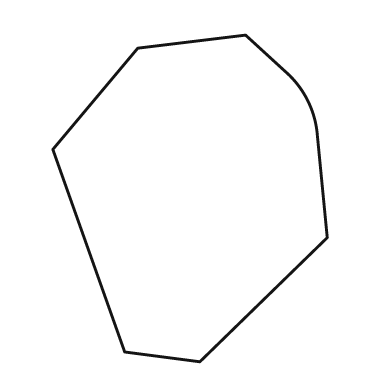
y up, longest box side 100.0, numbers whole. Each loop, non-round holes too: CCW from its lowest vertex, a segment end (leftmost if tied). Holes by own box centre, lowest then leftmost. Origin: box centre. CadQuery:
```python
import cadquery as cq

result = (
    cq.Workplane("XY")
    .moveTo(3.0, -50.0)
    .lineTo(42.0, -12.0)
    .lineTo(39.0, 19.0)
    .threePointArc((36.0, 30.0), (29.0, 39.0))
    .lineTo(17.0, 50.0)
    .lineTo(-16.0, 46.0)
    .lineTo(-42.0, 15.0)
    .lineTo(-20.0, -47.0)
    .close()
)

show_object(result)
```